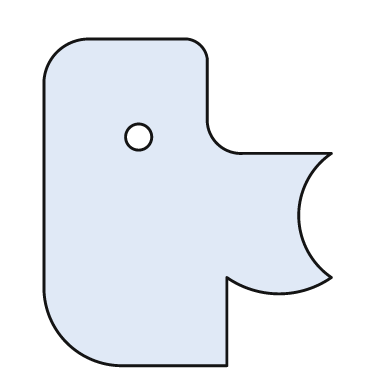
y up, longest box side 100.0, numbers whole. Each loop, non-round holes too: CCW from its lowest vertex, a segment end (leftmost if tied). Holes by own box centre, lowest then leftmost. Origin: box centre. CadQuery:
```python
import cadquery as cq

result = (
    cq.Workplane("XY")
    .moveTo(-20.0, -50.0)
    .lineTo(12.0, -50.0)
    .lineTo(12.0, -23.0)
    .threePointArc((28.0, -28.0), (44.0, -23.0))
    .threePointArc((34.0, -4.0), (44.0, 15.0))
    .lineTo(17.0, 15.0)
    .threePointArc((9.0, 18.0), (6.0, 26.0))
    .lineTo(6.0, 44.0)
    .threePointArc((4.0, 48.0), (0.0, 50.0))
    .lineTo(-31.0, 50.0)
    .threePointArc((-40.0, 46.0), (-44.0, 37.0))
    .lineTo(-44.0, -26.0)
    .threePointArc((-37.0, -43.0), (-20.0, -50.0))
    .close()
    .moveTo(-15.0, 20.0)
    .circle(4.0)
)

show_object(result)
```